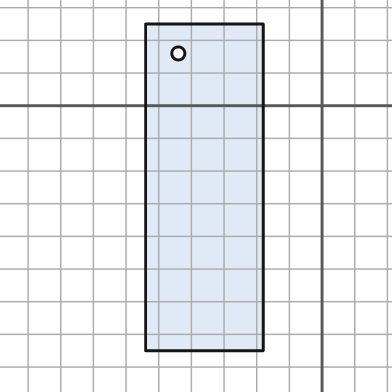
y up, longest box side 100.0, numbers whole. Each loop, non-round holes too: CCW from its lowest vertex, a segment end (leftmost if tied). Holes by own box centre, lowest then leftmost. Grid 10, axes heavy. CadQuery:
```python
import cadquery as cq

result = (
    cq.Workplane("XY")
    .moveTo(-54.0, -75.0)
    .lineTo(-18.0, -75.0)
    .lineTo(-18.0, 25.0)
    .lineTo(-54.0, 25.0)
    .close()
    .moveTo(-44.0, 16.0)
    .circle(2.0)
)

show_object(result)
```